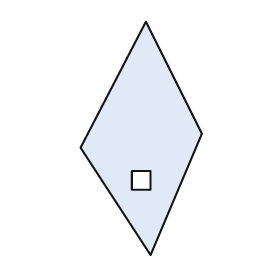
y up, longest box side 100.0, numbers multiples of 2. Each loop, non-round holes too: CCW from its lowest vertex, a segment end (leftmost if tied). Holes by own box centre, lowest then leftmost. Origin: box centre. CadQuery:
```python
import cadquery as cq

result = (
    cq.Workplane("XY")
    .moveTo(4.0, -50.0)
    .lineTo(26.0, 2.0)
    .lineTo(2.0, 50.0)
    .lineTo(-26.0, -4.0)
    .close()
    .moveTo(-4.0, -22.0)
    .lineTo(4.0, -22.0)
    .lineTo(4.0, -14.0)
    .lineTo(-4.0, -14.0)
    .close()
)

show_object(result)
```